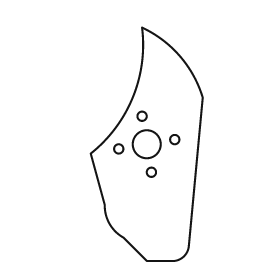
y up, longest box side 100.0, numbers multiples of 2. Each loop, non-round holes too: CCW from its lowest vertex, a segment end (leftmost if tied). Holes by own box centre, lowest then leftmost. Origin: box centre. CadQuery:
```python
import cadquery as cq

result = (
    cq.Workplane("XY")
    .moveTo(0.0, -50.0)
    .lineTo(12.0, -50.0)
    .threePointArc((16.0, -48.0), (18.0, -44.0))
    .lineTo(24.0, 20.0)
    .threePointArc((14.0, 38.0), (-2.0, 50.0))
    .threePointArc((-6.0, 20.0), (-24.0, -4.0))
    .lineTo(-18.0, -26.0)
    .threePointArc((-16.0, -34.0), (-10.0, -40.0))
    .close()
    .moveTo(2.0, -12.0)
    .circle(2.0)
    .moveTo(-12.0, -2.0)
    .circle(2.0)
    .moveTo(0.0, 0.0)
    .circle(6.0)
    .moveTo(12.0, 2.0)
    .circle(2.0)
    .moveTo(-2.0, 12.0)
    .circle(2.0)
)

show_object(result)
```